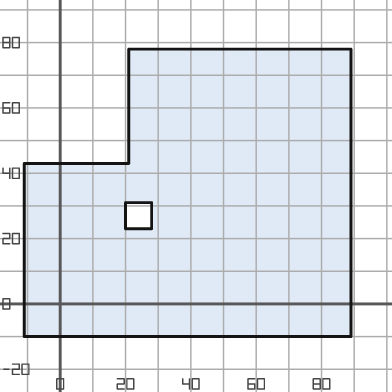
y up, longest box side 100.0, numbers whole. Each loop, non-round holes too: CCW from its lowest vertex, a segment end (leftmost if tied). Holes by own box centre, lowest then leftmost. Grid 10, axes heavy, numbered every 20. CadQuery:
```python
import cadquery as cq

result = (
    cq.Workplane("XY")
    .moveTo(-11.0, -10.0)
    .lineTo(89.0, -10.0)
    .lineTo(89.0, 78.0)
    .lineTo(21.0, 78.0)
    .lineTo(21.0, 43.0)
    .lineTo(-11.0, 43.0)
    .close()
    .moveTo(20.0, 23.0)
    .lineTo(28.0, 23.0)
    .lineTo(28.0, 31.0)
    .lineTo(20.0, 31.0)
    .close()
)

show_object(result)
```